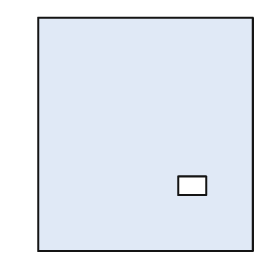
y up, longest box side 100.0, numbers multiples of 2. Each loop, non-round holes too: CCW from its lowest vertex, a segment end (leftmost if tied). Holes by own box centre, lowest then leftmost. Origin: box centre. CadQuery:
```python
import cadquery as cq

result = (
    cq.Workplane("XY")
    .moveTo(-46.0, -50.0)
    .lineTo(46.0, -50.0)
    .lineTo(46.0, 50.0)
    .lineTo(-46.0, 50.0)
    .close()
    .moveTo(14.0, -26.0)
    .lineTo(26.0, -26.0)
    .lineTo(26.0, -18.0)
    .lineTo(14.0, -18.0)
    .close()
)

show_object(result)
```